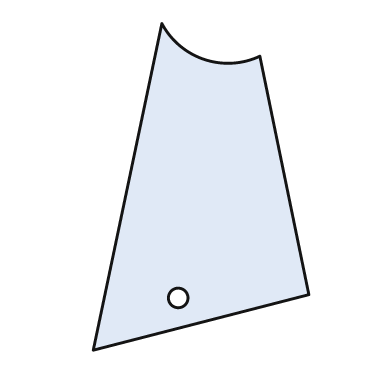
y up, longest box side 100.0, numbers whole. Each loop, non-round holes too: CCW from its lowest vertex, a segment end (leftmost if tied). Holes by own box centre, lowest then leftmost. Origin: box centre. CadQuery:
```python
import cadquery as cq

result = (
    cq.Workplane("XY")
    .moveTo(-33.0, -50.0)
    .lineTo(33.0, -33.0)
    .lineTo(18.0, 40.0)
    .threePointArc((1.0, 39.0), (-12.0, 50.0))
    .close()
    .moveTo(-7.0, -34.0)
    .circle(3.0)
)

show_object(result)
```